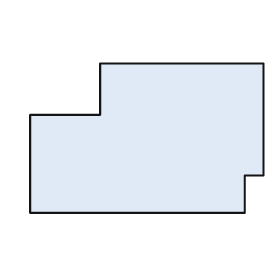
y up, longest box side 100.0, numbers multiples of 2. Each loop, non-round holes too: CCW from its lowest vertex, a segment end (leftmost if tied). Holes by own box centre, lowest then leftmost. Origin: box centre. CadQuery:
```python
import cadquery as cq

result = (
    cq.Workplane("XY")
    .moveTo(-50.0, -32.0)
    .lineTo(42.0, -32.0)
    .lineTo(42.0, -16.0)
    .lineTo(50.0, -16.0)
    .lineTo(50.0, 32.0)
    .lineTo(-20.0, 32.0)
    .lineTo(-20.0, 10.0)
    .lineTo(-50.0, 10.0)
    .close()
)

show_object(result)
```